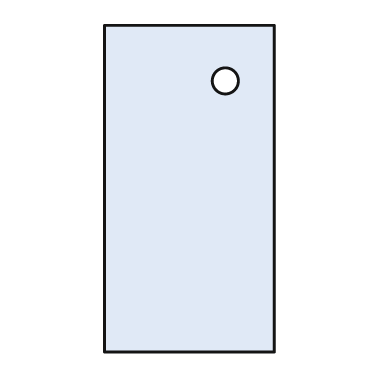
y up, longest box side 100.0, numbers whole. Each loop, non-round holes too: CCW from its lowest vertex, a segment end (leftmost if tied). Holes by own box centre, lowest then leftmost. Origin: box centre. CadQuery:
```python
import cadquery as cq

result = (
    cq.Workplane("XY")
    .moveTo(-26.0, -50.0)
    .lineTo(26.0, -50.0)
    .lineTo(26.0, 50.0)
    .lineTo(-26.0, 50.0)
    .close()
    .moveTo(11.0, 33.0)
    .circle(4.0)
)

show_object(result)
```